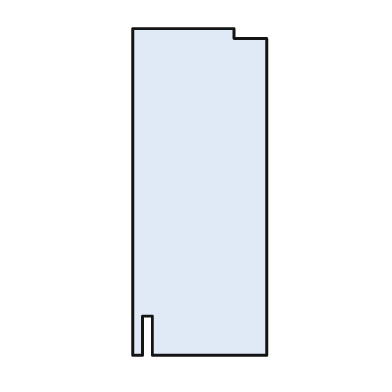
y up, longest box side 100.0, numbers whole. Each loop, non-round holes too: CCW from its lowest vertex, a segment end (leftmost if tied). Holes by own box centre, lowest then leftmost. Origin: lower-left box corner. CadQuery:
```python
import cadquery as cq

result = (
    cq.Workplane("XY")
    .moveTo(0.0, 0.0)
    .lineTo(3.0, 0.0)
    .lineTo(3.0, 12.0)
    .lineTo(6.0, 12.0)
    .lineTo(6.0, 0.0)
    .lineTo(41.0, 0.0)
    .lineTo(41.0, 97.0)
    .lineTo(31.0, 97.0)
    .lineTo(31.0, 100.0)
    .lineTo(0.0, 100.0)
    .close()
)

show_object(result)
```